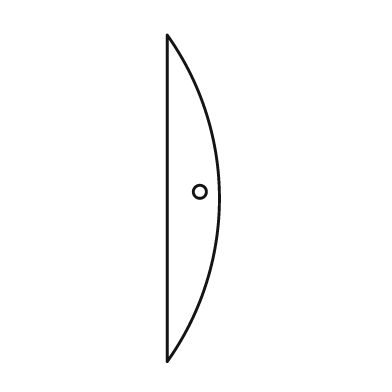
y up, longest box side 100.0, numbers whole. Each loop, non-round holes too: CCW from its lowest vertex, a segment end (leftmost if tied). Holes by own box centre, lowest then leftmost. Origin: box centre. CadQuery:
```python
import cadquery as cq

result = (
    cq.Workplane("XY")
    .moveTo(-8.0, -50.0)
    .threePointArc((8.0, 0.0), (-8.0, 50.0))
    .close()
    .moveTo(2.0, 2.0)
    .circle(2.0)
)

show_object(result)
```